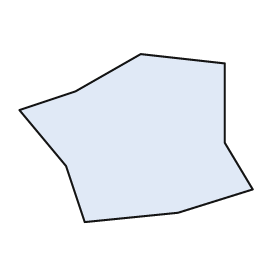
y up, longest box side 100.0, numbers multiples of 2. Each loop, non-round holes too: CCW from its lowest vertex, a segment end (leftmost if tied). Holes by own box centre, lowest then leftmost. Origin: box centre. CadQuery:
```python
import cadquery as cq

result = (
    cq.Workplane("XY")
    .moveTo(-22.0, -36.0)
    .lineTo(18.0, -32.0)
    .lineTo(50.0, -22.0)
    .lineTo(38.0, -2.0)
    .lineTo(38.0, 32.0)
    .lineTo(2.0, 36.0)
    .lineTo(-26.0, 20.0)
    .lineTo(-50.0, 12.0)
    .lineTo(-30.0, -12.0)
    .close()
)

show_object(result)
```